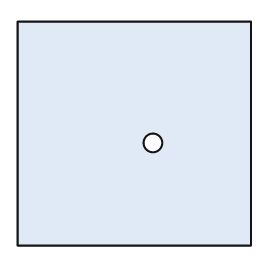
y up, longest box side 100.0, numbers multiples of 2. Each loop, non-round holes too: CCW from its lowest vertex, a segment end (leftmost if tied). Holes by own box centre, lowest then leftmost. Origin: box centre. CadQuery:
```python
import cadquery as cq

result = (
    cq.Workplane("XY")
    .moveTo(-50.0, -48.0)
    .lineTo(50.0, -48.0)
    .lineTo(50.0, 48.0)
    .lineTo(-50.0, 48.0)
    .close()
    .moveTo(8.0, -4.0)
    .circle(4.0)
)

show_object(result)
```